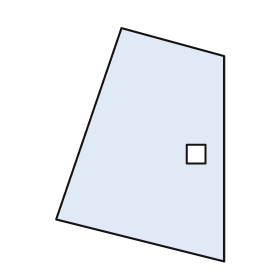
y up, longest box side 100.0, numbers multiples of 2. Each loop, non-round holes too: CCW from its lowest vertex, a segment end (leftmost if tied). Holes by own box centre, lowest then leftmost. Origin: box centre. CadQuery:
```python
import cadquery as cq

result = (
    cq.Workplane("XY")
    .moveTo(36.0, -50.0)
    .lineTo(36.0, 38.0)
    .lineTo(-8.0, 50.0)
    .lineTo(-36.0, -32.0)
    .close()
    .moveTo(20.0, -8.0)
    .lineTo(28.0, -8.0)
    .lineTo(28.0, 0.0)
    .lineTo(20.0, 0.0)
    .close()
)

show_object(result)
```